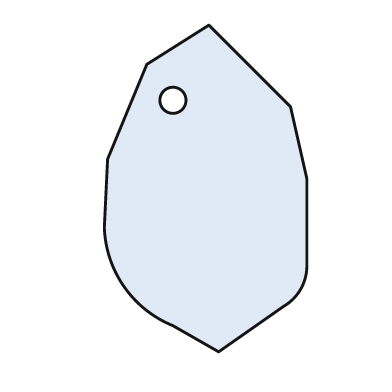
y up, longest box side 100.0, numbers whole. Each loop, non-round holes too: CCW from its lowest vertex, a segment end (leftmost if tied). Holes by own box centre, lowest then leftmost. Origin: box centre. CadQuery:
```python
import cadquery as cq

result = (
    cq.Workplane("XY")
    .moveTo(4.0, -50.0)
    .lineTo(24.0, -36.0)
    .threePointArc((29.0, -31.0), (31.0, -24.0))
    .lineTo(31.0, 3.0)
    .lineTo(26.0, 25.0)
    .lineTo(1.0, 50.0)
    .lineTo(-18.0, 38.0)
    .lineTo(-30.0, 9.0)
    .lineTo(-31.0, -12.0)
    .threePointArc((-25.0, -30.0), (-10.0, -42.0))
    .close()
    .moveTo(-10.0, 27.0)
    .circle(4.0)
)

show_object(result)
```